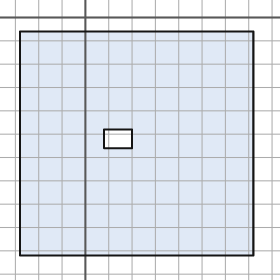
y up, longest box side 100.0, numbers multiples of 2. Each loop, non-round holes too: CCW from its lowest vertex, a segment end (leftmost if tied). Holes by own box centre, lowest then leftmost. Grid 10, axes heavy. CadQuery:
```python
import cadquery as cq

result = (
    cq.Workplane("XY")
    .moveTo(-28.0, -102.0)
    .lineTo(72.0, -102.0)
    .lineTo(72.0, -6.0)
    .lineTo(-28.0, -6.0)
    .close()
    .moveTo(8.0, -56.0)
    .lineTo(20.0, -56.0)
    .lineTo(20.0, -48.0)
    .lineTo(8.0, -48.0)
    .close()
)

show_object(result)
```